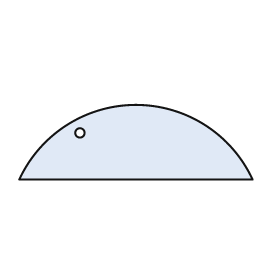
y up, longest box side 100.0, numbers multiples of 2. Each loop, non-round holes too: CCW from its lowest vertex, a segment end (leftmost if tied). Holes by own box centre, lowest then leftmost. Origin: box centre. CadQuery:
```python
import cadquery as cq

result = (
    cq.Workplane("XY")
    .moveTo(-50.0, -16.0)
    .lineTo(50.0, -16.0)
    .threePointArc((0.0, 16.0), (-50.0, -16.0))
    .close()
    .moveTo(-24.0, 4.0)
    .circle(2.0)
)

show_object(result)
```